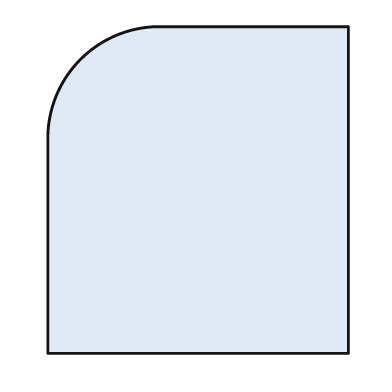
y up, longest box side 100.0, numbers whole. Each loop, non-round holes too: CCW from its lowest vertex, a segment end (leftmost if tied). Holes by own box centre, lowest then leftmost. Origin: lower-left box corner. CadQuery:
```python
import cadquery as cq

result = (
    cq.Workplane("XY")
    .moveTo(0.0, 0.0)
    .lineTo(92.0, 0.0)
    .lineTo(92.0, 100.0)
    .lineTo(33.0, 100.0)
    .threePointArc((10.0, 90.0), (0.0, 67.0))
    .close()
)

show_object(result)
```